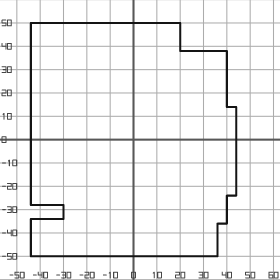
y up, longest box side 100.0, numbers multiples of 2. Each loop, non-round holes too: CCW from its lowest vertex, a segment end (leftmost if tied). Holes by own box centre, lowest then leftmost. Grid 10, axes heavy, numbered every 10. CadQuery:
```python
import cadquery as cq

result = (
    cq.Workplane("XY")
    .moveTo(-44.0, -50.0)
    .lineTo(36.0, -50.0)
    .lineTo(36.0, -36.0)
    .lineTo(40.0, -36.0)
    .lineTo(40.0, -24.0)
    .lineTo(44.0, -24.0)
    .lineTo(44.0, 14.0)
    .lineTo(40.0, 14.0)
    .lineTo(40.0, 38.0)
    .lineTo(20.0, 38.0)
    .lineTo(20.0, 50.0)
    .lineTo(-44.0, 50.0)
    .lineTo(-44.0, -28.0)
    .lineTo(-30.0, -28.0)
    .lineTo(-30.0, -34.0)
    .lineTo(-44.0, -34.0)
    .close()
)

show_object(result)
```